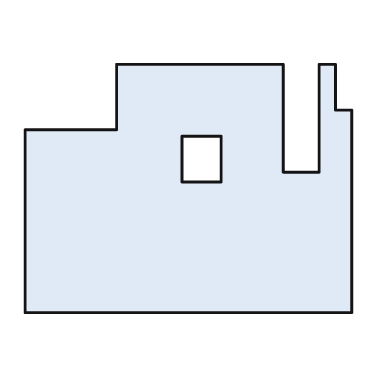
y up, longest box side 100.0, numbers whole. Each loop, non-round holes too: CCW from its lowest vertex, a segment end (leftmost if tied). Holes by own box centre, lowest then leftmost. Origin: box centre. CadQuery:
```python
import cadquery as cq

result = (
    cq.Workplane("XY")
    .moveTo(-50.0, -38.0)
    .lineTo(50.0, -38.0)
    .lineTo(50.0, 24.0)
    .lineTo(45.0, 24.0)
    .lineTo(45.0, 38.0)
    .lineTo(40.0, 38.0)
    .lineTo(40.0, 5.0)
    .lineTo(29.0, 5.0)
    .lineTo(29.0, 38.0)
    .lineTo(-22.0, 38.0)
    .lineTo(-22.0, 18.0)
    .lineTo(-50.0, 18.0)
    .close()
    .moveTo(-2.0, 2.0)
    .lineTo(10.0, 2.0)
    .lineTo(10.0, 16.0)
    .lineTo(-2.0, 16.0)
    .close()
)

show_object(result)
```